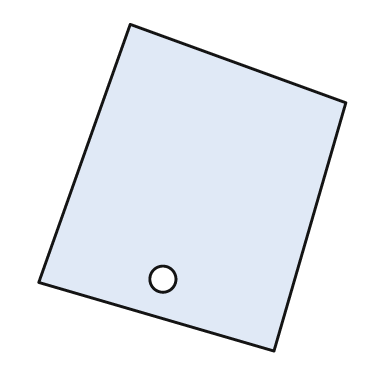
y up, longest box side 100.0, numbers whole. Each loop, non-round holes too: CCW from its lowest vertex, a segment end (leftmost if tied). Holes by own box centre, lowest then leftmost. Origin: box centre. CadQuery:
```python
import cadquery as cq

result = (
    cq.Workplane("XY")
    .moveTo(25.0, -50.0)
    .lineTo(47.0, 26.0)
    .lineTo(-19.0, 50.0)
    .lineTo(-47.0, -29.0)
    .close()
    .moveTo(-9.0, -28.0)
    .circle(4.0)
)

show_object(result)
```